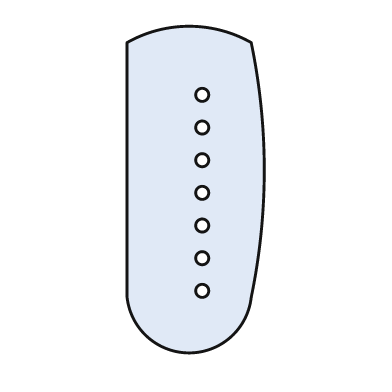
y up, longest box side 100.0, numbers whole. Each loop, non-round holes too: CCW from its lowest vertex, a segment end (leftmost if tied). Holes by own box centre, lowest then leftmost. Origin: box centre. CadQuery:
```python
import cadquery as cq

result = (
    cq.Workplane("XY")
    .moveTo(-21.0, -33.0)
    .threePointArc((-2.0, -50.0), (17.0, -33.0))
    .threePointArc((21.0, 6.0), (17.0, 45.0))
    .threePointArc((-2.0, 50.0), (-21.0, 45.0))
    .close()
    .moveTo(2.0, -31.0)
    .circle(2.0)
    .moveTo(2.0, -21.0)
    .circle(2.0)
    .moveTo(2.0, -11.0)
    .circle(2.0)
    .moveTo(2.0, -1.0)
    .circle(2.0)
    .moveTo(2.0, 9.0)
    .circle(2.0)
    .moveTo(2.0, 19.0)
    .circle(2.0)
    .moveTo(2.0, 29.0)
    .circle(2.0)
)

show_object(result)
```